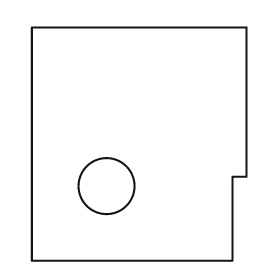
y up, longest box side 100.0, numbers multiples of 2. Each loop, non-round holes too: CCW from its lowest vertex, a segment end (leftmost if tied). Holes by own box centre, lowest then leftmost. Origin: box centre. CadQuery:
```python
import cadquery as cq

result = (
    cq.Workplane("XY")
    .moveTo(-46.0, -50.0)
    .lineTo(40.0, -50.0)
    .lineTo(40.0, -14.0)
    .lineTo(46.0, -14.0)
    .lineTo(46.0, 50.0)
    .lineTo(-46.0, 50.0)
    .close()
    .moveTo(-14.0, -18.0)
    .circle(12.0)
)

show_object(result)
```